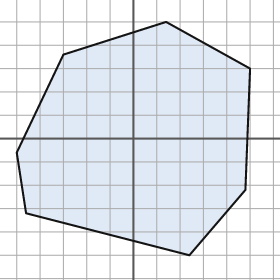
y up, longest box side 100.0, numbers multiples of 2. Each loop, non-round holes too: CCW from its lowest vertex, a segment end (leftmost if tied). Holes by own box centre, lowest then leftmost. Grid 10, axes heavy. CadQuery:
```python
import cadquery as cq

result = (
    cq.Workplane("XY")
    .moveTo(24.0, -50.0)
    .lineTo(48.0, -22.0)
    .lineTo(50.0, 30.0)
    .lineTo(14.0, 50.0)
    .lineTo(-30.0, 36.0)
    .lineTo(-50.0, -6.0)
    .lineTo(-46.0, -32.0)
    .close()
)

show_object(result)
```